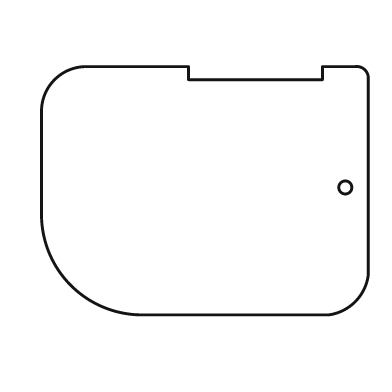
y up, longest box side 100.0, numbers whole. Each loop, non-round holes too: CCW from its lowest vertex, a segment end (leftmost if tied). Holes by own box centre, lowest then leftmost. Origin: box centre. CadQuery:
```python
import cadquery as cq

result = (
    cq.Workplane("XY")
    .moveTo(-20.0, -38.0)
    .lineTo(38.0, -38.0)
    .threePointArc((46.0, -34.0), (50.0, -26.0))
    .lineTo(50.0, 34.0)
    .threePointArc((49.0, 37.0), (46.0, 38.0))
    .lineTo(36.0, 38.0)
    .lineTo(36.0, 34.0)
    .lineTo(-5.0, 34.0)
    .lineTo(-5.0, 38.0)
    .lineTo(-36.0, 38.0)
    .threePointArc((-46.0, 34.0), (-50.0, 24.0))
    .lineTo(-50.0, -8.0)
    .threePointArc((-41.0, -29.0), (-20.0, -38.0))
    .close()
    .moveTo(43.0, 1.0)
    .circle(2.0)
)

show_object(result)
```